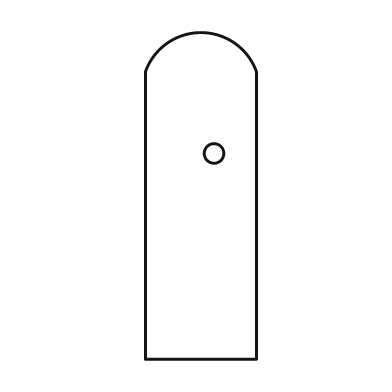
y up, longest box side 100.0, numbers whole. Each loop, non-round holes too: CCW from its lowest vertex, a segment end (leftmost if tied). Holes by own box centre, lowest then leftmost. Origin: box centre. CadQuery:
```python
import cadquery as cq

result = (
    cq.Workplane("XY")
    .moveTo(-17.0, -50.0)
    .lineTo(17.0, -50.0)
    .lineTo(17.0, 38.0)
    .threePointArc((0.0, 50.0), (-17.0, 38.0))
    .close()
    .moveTo(4.0, 13.0)
    .circle(3.0)
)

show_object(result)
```